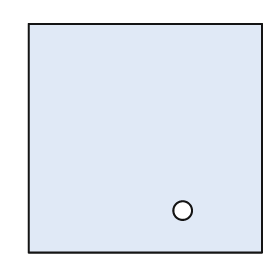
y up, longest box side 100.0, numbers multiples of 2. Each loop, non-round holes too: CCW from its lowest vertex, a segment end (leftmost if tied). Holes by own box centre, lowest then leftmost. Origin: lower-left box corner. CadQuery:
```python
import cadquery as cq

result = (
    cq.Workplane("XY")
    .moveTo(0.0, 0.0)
    .lineTo(100.0, 0.0)
    .lineTo(100.0, 98.0)
    .lineTo(0.0, 98.0)
    .close()
    .moveTo(66.0, 18.0)
    .circle(4.0)
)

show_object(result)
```